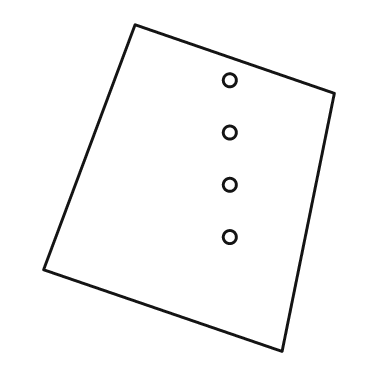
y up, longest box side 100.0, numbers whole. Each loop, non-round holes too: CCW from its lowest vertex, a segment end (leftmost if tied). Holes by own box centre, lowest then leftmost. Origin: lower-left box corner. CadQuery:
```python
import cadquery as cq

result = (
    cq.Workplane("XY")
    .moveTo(73.0, 0.0)
    .lineTo(89.0, 79.0)
    .lineTo(28.0, 100.0)
    .lineTo(0.0, 25.0)
    .close()
    .moveTo(57.0, 35.0)
    .circle(2.0)
    .moveTo(57.0, 51.0)
    .circle(2.0)
    .moveTo(57.0, 67.0)
    .circle(2.0)
    .moveTo(57.0, 83.0)
    .circle(2.0)
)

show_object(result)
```